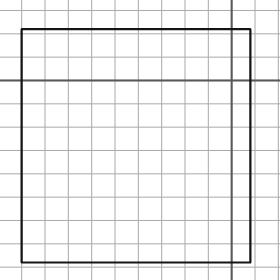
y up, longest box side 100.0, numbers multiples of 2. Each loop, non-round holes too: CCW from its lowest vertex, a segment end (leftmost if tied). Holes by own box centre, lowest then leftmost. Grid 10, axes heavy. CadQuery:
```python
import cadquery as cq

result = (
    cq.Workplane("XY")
    .moveTo(-90.0, -78.0)
    .lineTo(8.0, -78.0)
    .lineTo(8.0, 22.0)
    .lineTo(-90.0, 22.0)
    .close()
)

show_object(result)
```